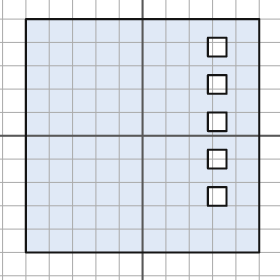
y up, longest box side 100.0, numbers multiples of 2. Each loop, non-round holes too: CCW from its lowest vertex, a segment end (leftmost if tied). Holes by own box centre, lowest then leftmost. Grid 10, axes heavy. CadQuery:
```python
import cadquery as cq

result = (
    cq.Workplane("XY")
    .moveTo(-50.0, -50.0)
    .lineTo(50.0, -50.0)
    .lineTo(50.0, 50.0)
    .lineTo(-50.0, 50.0)
    .close()
    .moveTo(28.0, -30.0)
    .lineTo(36.0, -30.0)
    .lineTo(36.0, -22.0)
    .lineTo(28.0, -22.0)
    .close()
    .moveTo(28.0, -14.0)
    .lineTo(36.0, -14.0)
    .lineTo(36.0, -6.0)
    .lineTo(28.0, -6.0)
    .close()
    .moveTo(28.0, 2.0)
    .lineTo(36.0, 2.0)
    .lineTo(36.0, 10.0)
    .lineTo(28.0, 10.0)
    .close()
    .moveTo(28.0, 18.0)
    .lineTo(36.0, 18.0)
    .lineTo(36.0, 26.0)
    .lineTo(28.0, 26.0)
    .close()
    .moveTo(28.0, 34.0)
    .lineTo(36.0, 34.0)
    .lineTo(36.0, 42.0)
    .lineTo(28.0, 42.0)
    .close()
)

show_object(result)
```